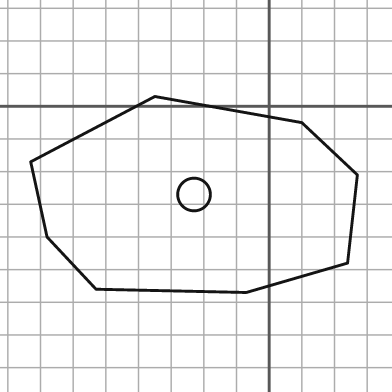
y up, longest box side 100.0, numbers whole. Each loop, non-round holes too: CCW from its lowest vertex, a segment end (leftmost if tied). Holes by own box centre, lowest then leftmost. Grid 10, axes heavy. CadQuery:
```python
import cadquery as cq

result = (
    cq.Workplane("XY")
    .moveTo(-7.0, -57.0)
    .lineTo(24.0, -48.0)
    .lineTo(27.0, -21.0)
    .lineTo(10.0, -5.0)
    .lineTo(-35.0, 3.0)
    .lineTo(-73.0, -17.0)
    .lineTo(-68.0, -40.0)
    .lineTo(-53.0, -56.0)
    .close()
    .moveTo(-23.0, -27.0)
    .circle(5.0)
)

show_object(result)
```